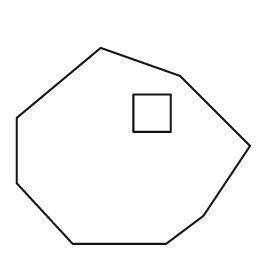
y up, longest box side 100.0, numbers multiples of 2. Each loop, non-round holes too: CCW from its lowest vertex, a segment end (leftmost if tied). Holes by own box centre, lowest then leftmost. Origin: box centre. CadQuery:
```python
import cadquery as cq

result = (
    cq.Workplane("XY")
    .moveTo(-26.0, -42.0)
    .lineTo(14.0, -42.0)
    .lineTo(30.0, -30.0)
    .lineTo(50.0, 0.0)
    .lineTo(20.0, 30.0)
    .lineTo(-14.0, 42.0)
    .lineTo(-50.0, 12.0)
    .lineTo(-50.0, -16.0)
    .close()
    .moveTo(0.0, 6.0)
    .lineTo(16.0, 6.0)
    .lineTo(16.0, 22.0)
    .lineTo(0.0, 22.0)
    .close()
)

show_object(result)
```